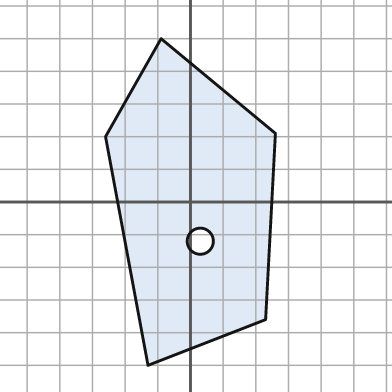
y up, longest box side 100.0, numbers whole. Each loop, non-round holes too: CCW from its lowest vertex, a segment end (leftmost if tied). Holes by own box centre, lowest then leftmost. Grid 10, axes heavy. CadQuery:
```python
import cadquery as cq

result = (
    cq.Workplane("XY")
    .moveTo(-13.0, -50.0)
    .lineTo(23.0, -36.0)
    .lineTo(26.0, 21.0)
    .lineTo(-9.0, 50.0)
    .lineTo(-26.0, 20.0)
    .close()
    .moveTo(3.0, -12.0)
    .circle(4.0)
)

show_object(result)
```